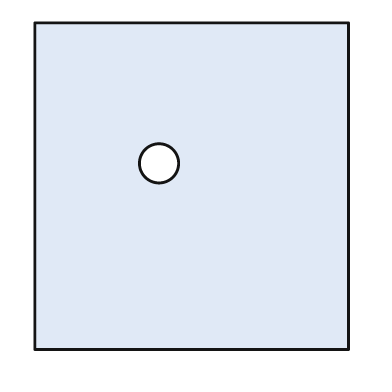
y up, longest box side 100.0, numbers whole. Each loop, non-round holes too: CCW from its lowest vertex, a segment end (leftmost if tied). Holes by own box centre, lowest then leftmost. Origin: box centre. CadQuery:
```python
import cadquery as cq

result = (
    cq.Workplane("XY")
    .moveTo(-48.0, -50.0)
    .lineTo(48.0, -50.0)
    .lineTo(48.0, 50.0)
    .lineTo(-48.0, 50.0)
    .close()
    .moveTo(-10.0, 7.0)
    .circle(6.0)
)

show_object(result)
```